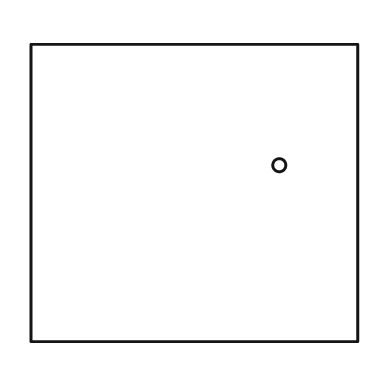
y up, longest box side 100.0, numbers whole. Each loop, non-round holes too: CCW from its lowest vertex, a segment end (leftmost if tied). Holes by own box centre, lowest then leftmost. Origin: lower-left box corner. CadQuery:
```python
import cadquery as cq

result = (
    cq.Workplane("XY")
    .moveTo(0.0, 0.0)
    .lineTo(100.0, 0.0)
    .lineTo(100.0, 91.0)
    .lineTo(0.0, 91.0)
    .close()
    .moveTo(76.0, 54.0)
    .circle(2.0)
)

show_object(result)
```